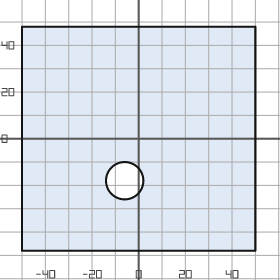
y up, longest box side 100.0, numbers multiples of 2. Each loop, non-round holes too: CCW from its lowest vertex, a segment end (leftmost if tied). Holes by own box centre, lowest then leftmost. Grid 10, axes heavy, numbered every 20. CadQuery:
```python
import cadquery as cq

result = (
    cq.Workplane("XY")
    .moveTo(-50.0, -48.0)
    .lineTo(50.0, -48.0)
    .lineTo(50.0, 48.0)
    .lineTo(-50.0, 48.0)
    .close()
    .moveTo(-6.0, -18.0)
    .circle(8.0)
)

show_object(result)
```